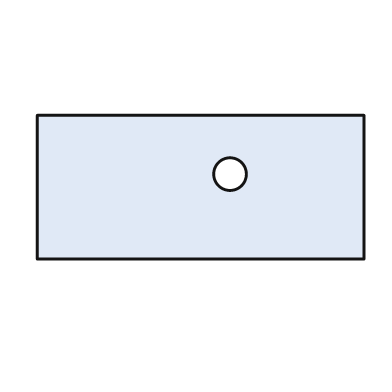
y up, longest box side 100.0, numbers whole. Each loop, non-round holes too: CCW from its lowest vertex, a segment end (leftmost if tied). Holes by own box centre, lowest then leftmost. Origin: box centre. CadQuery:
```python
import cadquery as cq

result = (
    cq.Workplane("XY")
    .moveTo(-50.0, -22.0)
    .lineTo(50.0, -22.0)
    .lineTo(50.0, 22.0)
    .lineTo(-50.0, 22.0)
    .close()
    .moveTo(9.0, 4.0)
    .circle(5.0)
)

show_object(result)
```